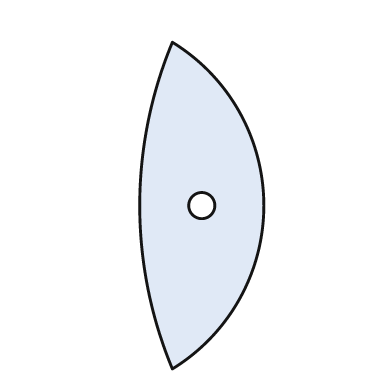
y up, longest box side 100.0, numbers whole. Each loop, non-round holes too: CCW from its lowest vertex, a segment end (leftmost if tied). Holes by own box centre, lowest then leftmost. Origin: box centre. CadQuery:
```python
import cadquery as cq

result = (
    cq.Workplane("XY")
    .moveTo(-9.0, -50.0)
    .threePointArc((19.0, 0.0), (-9.0, 50.0))
    .threePointArc((-19.0, 0.0), (-9.0, -50.0))
    .close()
    .moveTo(0.0, 0.0)
    .circle(4.0)
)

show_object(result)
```